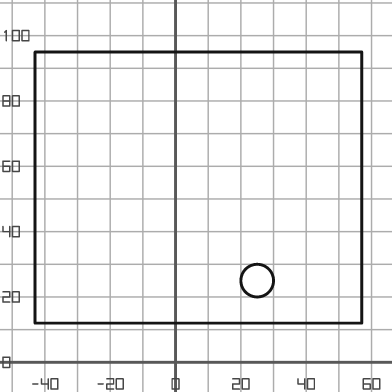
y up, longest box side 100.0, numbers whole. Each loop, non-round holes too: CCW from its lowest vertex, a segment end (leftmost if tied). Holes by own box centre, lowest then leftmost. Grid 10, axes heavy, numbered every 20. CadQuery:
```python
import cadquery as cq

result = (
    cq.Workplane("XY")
    .moveTo(-43.0, 12.0)
    .lineTo(57.0, 12.0)
    .lineTo(57.0, 95.0)
    .lineTo(-43.0, 95.0)
    .close()
    .moveTo(25.0, 25.0)
    .circle(5.0)
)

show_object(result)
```